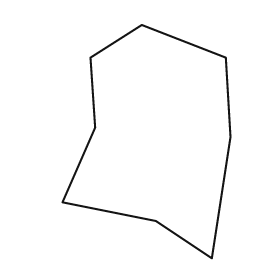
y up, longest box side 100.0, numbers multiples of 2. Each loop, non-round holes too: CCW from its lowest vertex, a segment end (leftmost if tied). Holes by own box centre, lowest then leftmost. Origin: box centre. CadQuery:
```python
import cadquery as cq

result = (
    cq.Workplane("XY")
    .moveTo(28.0, -50.0)
    .lineTo(36.0, 2.0)
    .lineTo(34.0, 36.0)
    .lineTo(-2.0, 50.0)
    .lineTo(-24.0, 36.0)
    .lineTo(-22.0, 6.0)
    .lineTo(-36.0, -26.0)
    .lineTo(4.0, -34.0)
    .close()
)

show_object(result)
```